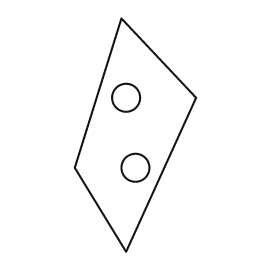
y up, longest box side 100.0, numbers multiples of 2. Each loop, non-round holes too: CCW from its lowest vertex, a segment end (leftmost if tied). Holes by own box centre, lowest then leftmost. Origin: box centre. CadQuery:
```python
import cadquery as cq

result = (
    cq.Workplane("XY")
    .moveTo(-4.0, -50.0)
    .lineTo(26.0, 16.0)
    .lineTo(-6.0, 50.0)
    .lineTo(-26.0, -14.0)
    .close()
    .moveTo(0.0, -14.0)
    .circle(6.0)
    .moveTo(-4.0, 16.0)
    .circle(6.0)
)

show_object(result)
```